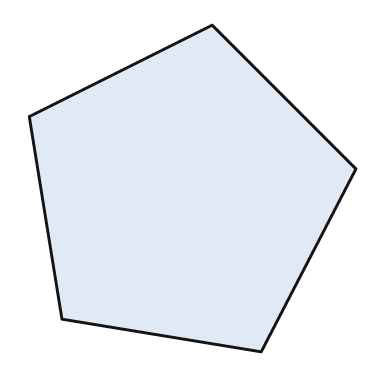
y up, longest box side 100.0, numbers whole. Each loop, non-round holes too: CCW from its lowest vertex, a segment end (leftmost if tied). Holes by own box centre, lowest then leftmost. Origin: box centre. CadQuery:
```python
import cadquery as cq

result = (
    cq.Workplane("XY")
    .moveTo(21.0, -50.0)
    .lineTo(50.0, 6.0)
    .lineTo(6.0, 50.0)
    .lineTo(-50.0, 22.0)
    .lineTo(-40.0, -40.0)
    .close()
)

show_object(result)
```